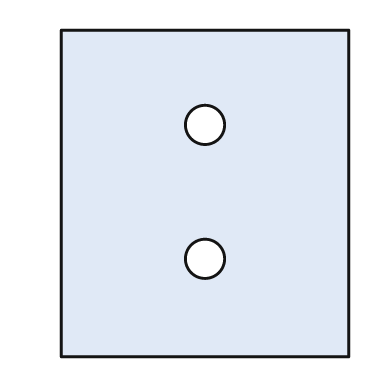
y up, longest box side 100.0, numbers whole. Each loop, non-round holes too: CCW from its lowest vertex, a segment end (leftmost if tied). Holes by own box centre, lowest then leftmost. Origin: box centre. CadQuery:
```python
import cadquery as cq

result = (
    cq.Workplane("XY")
    .moveTo(-44.0, -50.0)
    .lineTo(44.0, -50.0)
    .lineTo(44.0, 50.0)
    .lineTo(-44.0, 50.0)
    .close()
    .moveTo(0.0, -20.0)
    .circle(6.0)
    .moveTo(0.0, 21.0)
    .circle(6.0)
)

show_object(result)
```